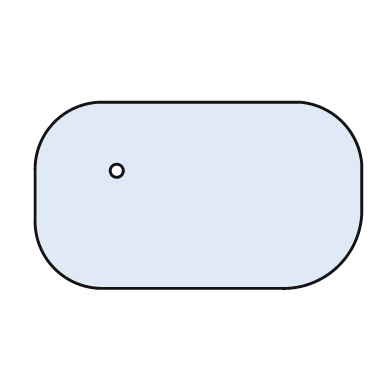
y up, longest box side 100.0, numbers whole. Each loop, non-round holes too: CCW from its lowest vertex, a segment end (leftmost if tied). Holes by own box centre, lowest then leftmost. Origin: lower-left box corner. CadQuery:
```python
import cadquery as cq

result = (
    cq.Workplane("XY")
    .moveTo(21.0, 0.0)
    .lineTo(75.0, 0.0)
    .threePointArc((93.0, 7.0), (100.0, 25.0))
    .lineTo(100.0, 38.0)
    .threePointArc((94.0, 51.0), (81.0, 57.0))
    .lineTo(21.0, 57.0)
    .threePointArc((6.0, 51.0), (0.0, 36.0))
    .lineTo(0.0, 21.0)
    .threePointArc((6.0, 6.0), (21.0, 0.0))
    .close()
    .moveTo(25.0, 36.0)
    .circle(2.0)
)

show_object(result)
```